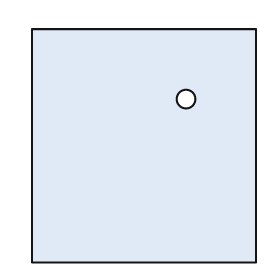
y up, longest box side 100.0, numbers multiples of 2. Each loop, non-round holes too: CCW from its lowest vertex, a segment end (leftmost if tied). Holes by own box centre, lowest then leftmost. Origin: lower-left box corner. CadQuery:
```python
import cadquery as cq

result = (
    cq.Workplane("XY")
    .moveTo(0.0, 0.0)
    .lineTo(96.0, 0.0)
    .lineTo(96.0, 100.0)
    .lineTo(0.0, 100.0)
    .close()
    .moveTo(66.0, 70.0)
    .circle(4.0)
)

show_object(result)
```